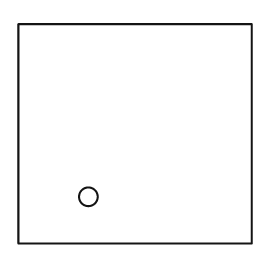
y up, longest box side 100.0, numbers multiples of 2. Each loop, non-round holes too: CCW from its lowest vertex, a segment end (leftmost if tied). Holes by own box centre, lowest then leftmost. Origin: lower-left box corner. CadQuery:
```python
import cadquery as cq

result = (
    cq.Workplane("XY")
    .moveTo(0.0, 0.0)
    .lineTo(100.0, 0.0)
    .lineTo(100.0, 94.0)
    .lineTo(0.0, 94.0)
    .close()
    .moveTo(30.0, 20.0)
    .circle(4.0)
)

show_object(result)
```